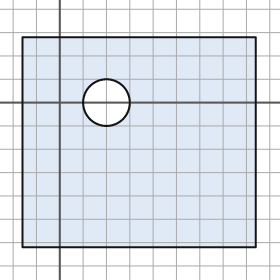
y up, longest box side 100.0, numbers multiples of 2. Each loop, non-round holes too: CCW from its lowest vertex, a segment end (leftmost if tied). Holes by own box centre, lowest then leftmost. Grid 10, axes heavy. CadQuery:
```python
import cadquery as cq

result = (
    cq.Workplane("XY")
    .moveTo(-16.0, -62.0)
    .lineTo(84.0, -62.0)
    .lineTo(84.0, 28.0)
    .lineTo(-16.0, 28.0)
    .close()
    .moveTo(20.0, 0.0)
    .circle(10.0)
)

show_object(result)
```